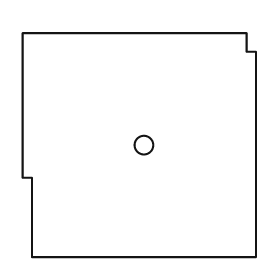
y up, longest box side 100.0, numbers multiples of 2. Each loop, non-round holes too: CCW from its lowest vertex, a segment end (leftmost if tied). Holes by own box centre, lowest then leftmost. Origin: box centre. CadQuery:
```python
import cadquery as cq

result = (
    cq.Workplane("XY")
    .moveTo(-46.0, -48.0)
    .lineTo(50.0, -48.0)
    .lineTo(50.0, 40.0)
    .lineTo(46.0, 40.0)
    .lineTo(46.0, 48.0)
    .lineTo(-50.0, 48.0)
    .lineTo(-50.0, -14.0)
    .lineTo(-46.0, -14.0)
    .close()
    .moveTo(2.0, 0.0)
    .circle(4.0)
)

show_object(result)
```